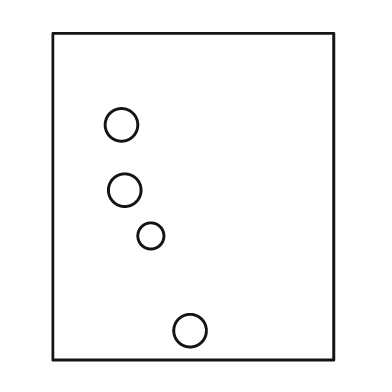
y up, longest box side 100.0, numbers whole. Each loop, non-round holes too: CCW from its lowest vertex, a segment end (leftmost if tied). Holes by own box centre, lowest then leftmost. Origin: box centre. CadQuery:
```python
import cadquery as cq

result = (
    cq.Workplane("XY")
    .moveTo(-43.0, -50.0)
    .lineTo(43.0, -50.0)
    .lineTo(43.0, 50.0)
    .lineTo(-43.0, 50.0)
    .close()
    .moveTo(-1.0, -41.0)
    .circle(5.0)
    .moveTo(-13.0, -12.0)
    .circle(4.0)
    .moveTo(-21.0, 2.0)
    .circle(5.0)
    .moveTo(-22.0, 22.0)
    .circle(5.0)
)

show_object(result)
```